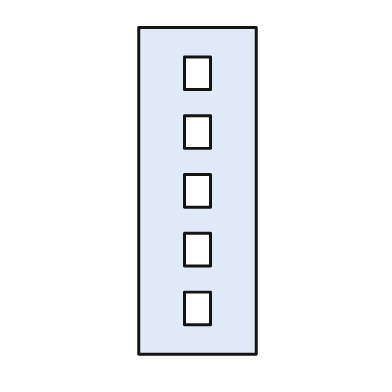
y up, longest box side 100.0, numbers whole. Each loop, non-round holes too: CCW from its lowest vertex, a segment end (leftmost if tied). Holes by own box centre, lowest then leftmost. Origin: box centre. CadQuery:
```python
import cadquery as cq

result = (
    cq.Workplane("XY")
    .moveTo(-18.0, -50.0)
    .lineTo(18.0, -50.0)
    .lineTo(18.0, 50.0)
    .lineTo(-18.0, 50.0)
    .close()
    .moveTo(-4.0, -41.0)
    .lineTo(4.0, -41.0)
    .lineTo(4.0, -31.0)
    .lineTo(-4.0, -31.0)
    .close()
    .moveTo(-4.0, -23.0)
    .lineTo(4.0, -23.0)
    .lineTo(4.0, -13.0)
    .lineTo(-4.0, -13.0)
    .close()
    .moveTo(-4.0, -5.0)
    .lineTo(4.0, -5.0)
    .lineTo(4.0, 5.0)
    .lineTo(-4.0, 5.0)
    .close()
    .moveTo(-4.0, 13.0)
    .lineTo(4.0, 13.0)
    .lineTo(4.0, 23.0)
    .lineTo(-4.0, 23.0)
    .close()
    .moveTo(-4.0, 31.0)
    .lineTo(4.0, 31.0)
    .lineTo(4.0, 41.0)
    .lineTo(-4.0, 41.0)
    .close()
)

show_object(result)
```